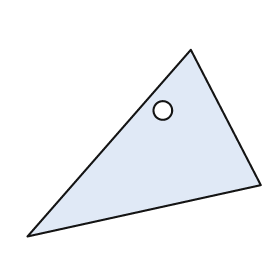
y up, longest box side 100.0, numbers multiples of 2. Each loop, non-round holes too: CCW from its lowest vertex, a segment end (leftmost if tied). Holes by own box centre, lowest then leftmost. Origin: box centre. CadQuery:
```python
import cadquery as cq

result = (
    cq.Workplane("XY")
    .moveTo(-50.0, -40.0)
    .lineTo(50.0, -18.0)
    .lineTo(20.0, 40.0)
    .close()
    .moveTo(8.0, 14.0)
    .circle(4.0)
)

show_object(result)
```